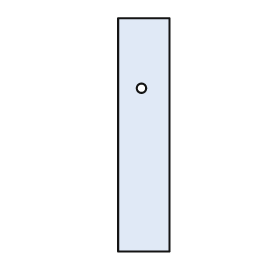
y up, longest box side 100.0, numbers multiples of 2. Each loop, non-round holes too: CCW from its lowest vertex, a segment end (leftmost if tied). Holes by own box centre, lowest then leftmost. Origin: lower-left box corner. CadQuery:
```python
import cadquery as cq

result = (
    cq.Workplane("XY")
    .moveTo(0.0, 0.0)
    .lineTo(22.0, 0.0)
    .lineTo(22.0, 100.0)
    .lineTo(0.0, 100.0)
    .close()
    .moveTo(10.0, 70.0)
    .circle(2.0)
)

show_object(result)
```